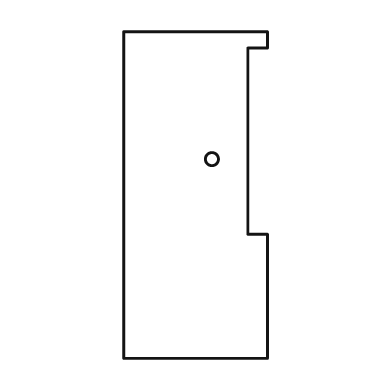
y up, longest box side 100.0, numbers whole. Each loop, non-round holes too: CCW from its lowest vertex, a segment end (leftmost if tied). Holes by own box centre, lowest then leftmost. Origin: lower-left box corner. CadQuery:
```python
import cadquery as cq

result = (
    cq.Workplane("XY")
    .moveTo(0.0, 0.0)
    .lineTo(44.0, 0.0)
    .lineTo(44.0, 38.0)
    .lineTo(38.0, 38.0)
    .lineTo(38.0, 95.0)
    .lineTo(44.0, 95.0)
    .lineTo(44.0, 100.0)
    .lineTo(0.0, 100.0)
    .close()
    .moveTo(27.0, 61.0)
    .circle(2.0)
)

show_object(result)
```